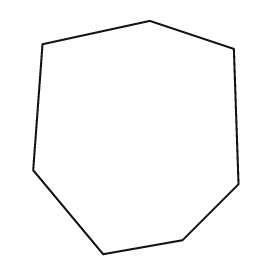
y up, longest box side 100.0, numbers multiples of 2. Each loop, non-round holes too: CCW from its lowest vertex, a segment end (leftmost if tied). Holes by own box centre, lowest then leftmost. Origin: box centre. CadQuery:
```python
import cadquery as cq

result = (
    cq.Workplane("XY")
    .moveTo(-14.0, -50.0)
    .lineTo(20.0, -44.0)
    .lineTo(44.0, -20.0)
    .lineTo(42.0, 38.0)
    .lineTo(6.0, 50.0)
    .lineTo(-40.0, 40.0)
    .lineTo(-44.0, -14.0)
    .close()
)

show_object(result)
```